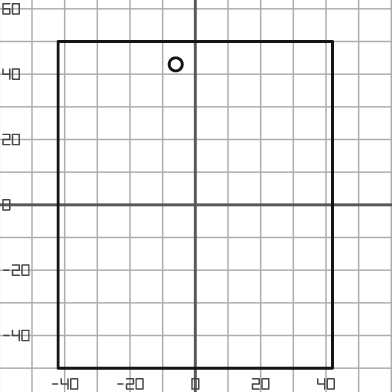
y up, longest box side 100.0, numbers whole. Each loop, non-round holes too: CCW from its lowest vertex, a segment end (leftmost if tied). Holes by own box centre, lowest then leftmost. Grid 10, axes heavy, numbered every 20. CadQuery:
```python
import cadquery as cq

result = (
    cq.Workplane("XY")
    .moveTo(-42.0, -50.0)
    .lineTo(42.0, -50.0)
    .lineTo(42.0, 50.0)
    .lineTo(-42.0, 50.0)
    .close()
    .moveTo(-6.0, 43.0)
    .circle(2.0)
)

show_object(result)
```